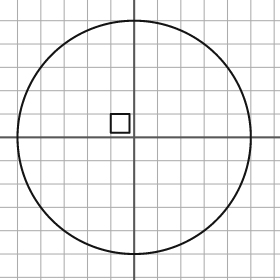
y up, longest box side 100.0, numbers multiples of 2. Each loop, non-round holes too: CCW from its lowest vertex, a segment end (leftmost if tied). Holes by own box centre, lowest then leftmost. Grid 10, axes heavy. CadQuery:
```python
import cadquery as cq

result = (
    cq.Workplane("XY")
    .moveTo(0.0, 0.0)
    .circle(50.0)
    .moveTo(-10.0, 2.0)
    .lineTo(-2.0, 2.0)
    .lineTo(-2.0, 10.0)
    .lineTo(-10.0, 10.0)
    .close()
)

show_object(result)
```